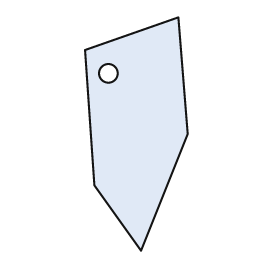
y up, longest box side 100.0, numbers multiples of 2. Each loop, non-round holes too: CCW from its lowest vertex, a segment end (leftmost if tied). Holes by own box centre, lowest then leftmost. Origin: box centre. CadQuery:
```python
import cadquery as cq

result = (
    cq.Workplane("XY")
    .moveTo(2.0, -50.0)
    .lineTo(22.0, 0.0)
    .lineTo(18.0, 50.0)
    .lineTo(-22.0, 36.0)
    .lineTo(-18.0, -22.0)
    .close()
    .moveTo(-12.0, 26.0)
    .circle(4.0)
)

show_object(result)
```